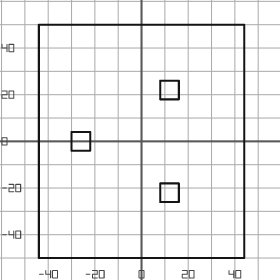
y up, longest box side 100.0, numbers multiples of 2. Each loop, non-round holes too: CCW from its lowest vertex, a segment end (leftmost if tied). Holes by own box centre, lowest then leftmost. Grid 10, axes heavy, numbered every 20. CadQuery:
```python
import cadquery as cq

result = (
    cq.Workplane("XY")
    .moveTo(-44.0, -50.0)
    .lineTo(44.0, -50.0)
    .lineTo(44.0, 50.0)
    .lineTo(-44.0, 50.0)
    .close()
    .moveTo(8.0, -26.0)
    .lineTo(16.0, -26.0)
    .lineTo(16.0, -18.0)
    .lineTo(8.0, -18.0)
    .close()
    .moveTo(-30.0, -4.0)
    .lineTo(-22.0, -4.0)
    .lineTo(-22.0, 4.0)
    .lineTo(-30.0, 4.0)
    .close()
    .moveTo(8.0, 18.0)
    .lineTo(16.0, 18.0)
    .lineTo(16.0, 26.0)
    .lineTo(8.0, 26.0)
    .close()
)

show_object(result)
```